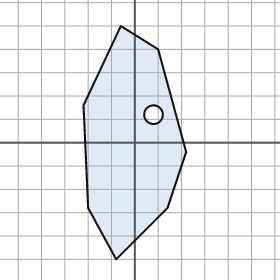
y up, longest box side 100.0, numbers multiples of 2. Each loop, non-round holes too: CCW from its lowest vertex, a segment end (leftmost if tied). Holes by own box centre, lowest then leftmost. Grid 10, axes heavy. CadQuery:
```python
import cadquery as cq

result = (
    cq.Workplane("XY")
    .moveTo(-8.0, -50.0)
    .lineTo(14.0, -28.0)
    .lineTo(22.0, -4.0)
    .lineTo(10.0, 40.0)
    .lineTo(-6.0, 50.0)
    .lineTo(-22.0, 16.0)
    .lineTo(-20.0, -28.0)
    .close()
    .moveTo(8.0, 12.0)
    .circle(4.0)
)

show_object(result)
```